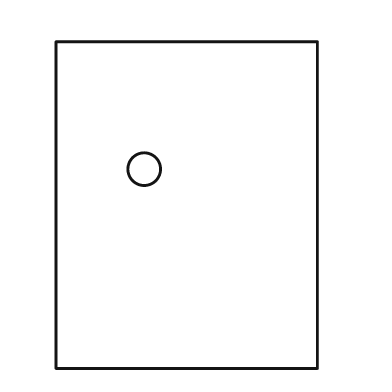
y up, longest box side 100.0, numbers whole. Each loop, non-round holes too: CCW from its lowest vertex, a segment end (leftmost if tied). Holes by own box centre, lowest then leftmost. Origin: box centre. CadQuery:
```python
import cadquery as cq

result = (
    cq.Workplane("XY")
    .moveTo(-40.0, -50.0)
    .lineTo(40.0, -50.0)
    .lineTo(40.0, 50.0)
    .lineTo(-40.0, 50.0)
    .close()
    .moveTo(-13.0, 11.0)
    .circle(5.0)
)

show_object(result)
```